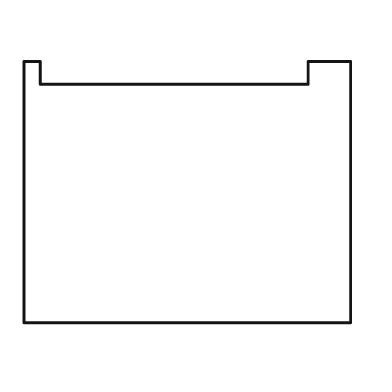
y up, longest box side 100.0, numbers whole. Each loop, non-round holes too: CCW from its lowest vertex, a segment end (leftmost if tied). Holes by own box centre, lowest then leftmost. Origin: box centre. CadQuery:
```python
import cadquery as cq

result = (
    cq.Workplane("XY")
    .moveTo(-50.0, -40.0)
    .lineTo(50.0, -40.0)
    .lineTo(50.0, 40.0)
    .lineTo(37.0, 40.0)
    .lineTo(37.0, 33.0)
    .lineTo(-45.0, 33.0)
    .lineTo(-45.0, 40.0)
    .lineTo(-50.0, 40.0)
    .close()
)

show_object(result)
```